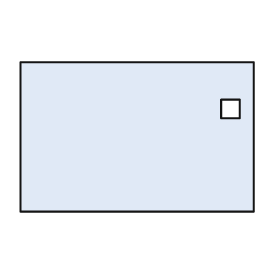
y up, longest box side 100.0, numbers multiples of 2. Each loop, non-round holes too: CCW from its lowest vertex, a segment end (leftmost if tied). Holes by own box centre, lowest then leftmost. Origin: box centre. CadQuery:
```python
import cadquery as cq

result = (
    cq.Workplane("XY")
    .moveTo(-50.0, -32.0)
    .lineTo(50.0, -32.0)
    .lineTo(50.0, 32.0)
    .lineTo(-50.0, 32.0)
    .close()
    .moveTo(36.0, 8.0)
    .lineTo(44.0, 8.0)
    .lineTo(44.0, 16.0)
    .lineTo(36.0, 16.0)
    .close()
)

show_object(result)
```